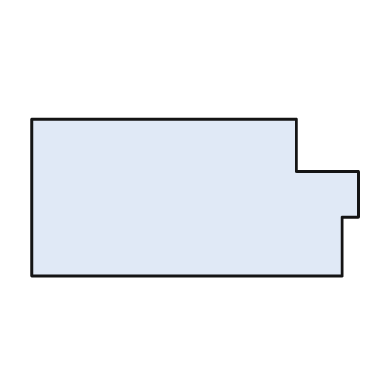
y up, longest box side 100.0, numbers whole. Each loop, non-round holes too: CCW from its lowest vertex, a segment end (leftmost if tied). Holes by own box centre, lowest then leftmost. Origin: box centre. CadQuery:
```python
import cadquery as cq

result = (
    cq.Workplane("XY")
    .moveTo(-50.0, -24.0)
    .lineTo(45.0, -24.0)
    .lineTo(45.0, -6.0)
    .lineTo(50.0, -6.0)
    .lineTo(50.0, 8.0)
    .lineTo(31.0, 8.0)
    .lineTo(31.0, 24.0)
    .lineTo(-50.0, 24.0)
    .close()
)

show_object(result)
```